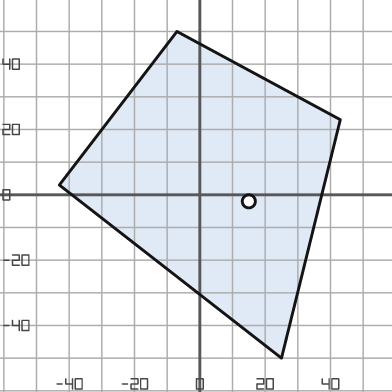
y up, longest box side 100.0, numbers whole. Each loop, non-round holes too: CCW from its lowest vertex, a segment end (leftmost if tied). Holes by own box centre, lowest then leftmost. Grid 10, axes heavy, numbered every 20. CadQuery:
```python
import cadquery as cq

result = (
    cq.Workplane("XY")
    .moveTo(25.0, -50.0)
    .lineTo(43.0, 23.0)
    .lineTo(-7.0, 50.0)
    .lineTo(-43.0, 3.0)
    .close()
    .moveTo(15.0, -2.0)
    .circle(2.0)
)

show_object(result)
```